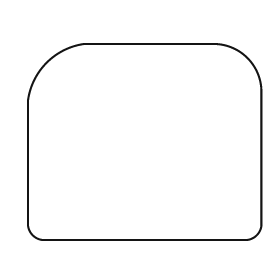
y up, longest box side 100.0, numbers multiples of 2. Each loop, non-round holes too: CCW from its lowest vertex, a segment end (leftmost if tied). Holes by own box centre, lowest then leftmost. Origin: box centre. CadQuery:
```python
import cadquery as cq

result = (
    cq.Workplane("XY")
    .moveTo(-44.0, -42.0)
    .lineTo(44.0, -42.0)
    .threePointArc((48.0, -40.0), (50.0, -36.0))
    .lineTo(50.0, 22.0)
    .threePointArc((44.0, 36.0), (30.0, 42.0))
    .lineTo(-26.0, 42.0)
    .threePointArc((-42.0, 34.0), (-50.0, 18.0))
    .lineTo(-50.0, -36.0)
    .threePointArc((-48.0, -40.0), (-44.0, -42.0))
    .close()
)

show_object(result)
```